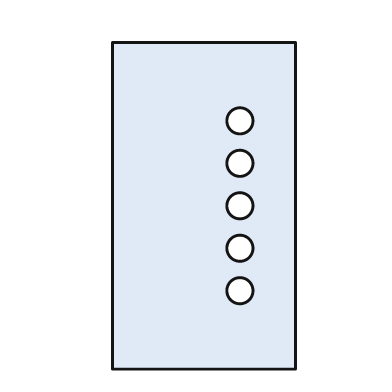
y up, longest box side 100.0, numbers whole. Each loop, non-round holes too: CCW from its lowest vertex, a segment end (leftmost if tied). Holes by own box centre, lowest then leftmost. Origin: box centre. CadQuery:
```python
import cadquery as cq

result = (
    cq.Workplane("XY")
    .moveTo(-28.0, -50.0)
    .lineTo(28.0, -50.0)
    .lineTo(28.0, 50.0)
    .lineTo(-28.0, 50.0)
    .close()
    .moveTo(11.0, -26.0)
    .circle(4.0)
    .moveTo(11.0, -13.0)
    .circle(4.0)
    .moveTo(11.0, 0.0)
    .circle(4.0)
    .moveTo(11.0, 13.0)
    .circle(4.0)
    .moveTo(11.0, 26.0)
    .circle(4.0)
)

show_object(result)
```